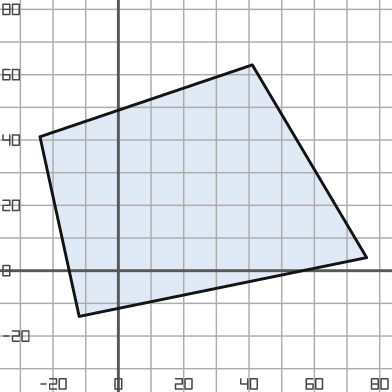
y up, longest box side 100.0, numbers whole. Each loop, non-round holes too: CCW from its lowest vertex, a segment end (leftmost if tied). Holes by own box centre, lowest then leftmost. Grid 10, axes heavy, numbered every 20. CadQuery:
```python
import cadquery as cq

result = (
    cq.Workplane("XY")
    .moveTo(-12.0, -14.0)
    .lineTo(76.0, 4.0)
    .lineTo(41.0, 63.0)
    .lineTo(-24.0, 41.0)
    .close()
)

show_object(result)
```